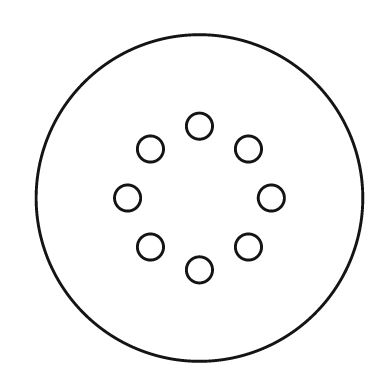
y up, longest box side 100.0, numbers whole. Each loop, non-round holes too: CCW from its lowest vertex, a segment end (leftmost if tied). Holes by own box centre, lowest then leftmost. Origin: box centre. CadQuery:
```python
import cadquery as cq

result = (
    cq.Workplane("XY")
    .moveTo(0.0, 0.0)
    .circle(50.0)
    .moveTo(0.0, -22.0)
    .circle(4.0)
    .moveTo(-15.0, -15.0)
    .circle(4.0)
    .moveTo(15.0, -15.0)
    .circle(4.0)
    .moveTo(-22.0, 0.0)
    .circle(4.0)
    .moveTo(22.0, 0.0)
    .circle(4.0)
    .moveTo(-15.0, 15.0)
    .circle(4.0)
    .moveTo(15.0, 15.0)
    .circle(4.0)
    .moveTo(0.0, 22.0)
    .circle(4.0)
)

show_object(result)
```